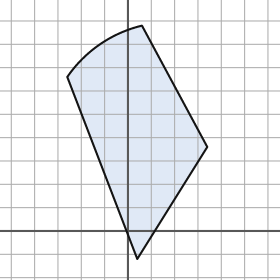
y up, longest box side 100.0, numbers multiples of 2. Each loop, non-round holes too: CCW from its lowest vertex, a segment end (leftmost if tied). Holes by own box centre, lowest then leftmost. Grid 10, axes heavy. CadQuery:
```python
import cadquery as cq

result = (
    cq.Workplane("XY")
    .moveTo(4.0, -12.0)
    .lineTo(34.0, 36.0)
    .lineTo(6.0, 88.0)
    .threePointArc((-12.0, 80.0), (-26.0, 66.0))
    .close()
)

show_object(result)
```